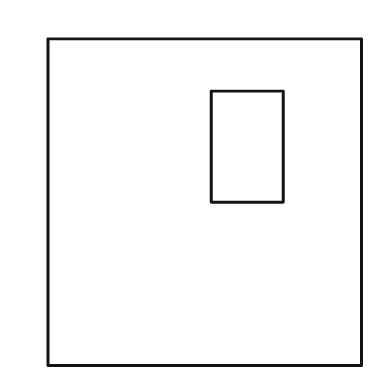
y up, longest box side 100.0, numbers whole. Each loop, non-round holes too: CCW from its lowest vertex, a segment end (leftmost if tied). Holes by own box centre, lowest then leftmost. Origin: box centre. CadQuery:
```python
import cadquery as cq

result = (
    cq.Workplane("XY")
    .moveTo(-48.0, -50.0)
    .lineTo(48.0, -50.0)
    .lineTo(48.0, 50.0)
    .lineTo(-48.0, 50.0)
    .close()
    .moveTo(2.0, 0.0)
    .lineTo(24.0, 0.0)
    .lineTo(24.0, 34.0)
    .lineTo(2.0, 34.0)
    .close()
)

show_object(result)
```